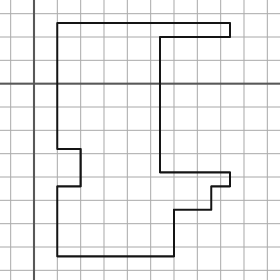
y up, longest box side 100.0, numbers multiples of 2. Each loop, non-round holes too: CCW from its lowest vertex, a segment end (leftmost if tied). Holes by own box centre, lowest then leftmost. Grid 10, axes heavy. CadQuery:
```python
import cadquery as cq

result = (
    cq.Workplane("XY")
    .moveTo(10.0, -74.0)
    .lineTo(60.0, -74.0)
    .lineTo(60.0, -54.0)
    .lineTo(76.0, -54.0)
    .lineTo(76.0, -44.0)
    .lineTo(84.0, -44.0)
    .lineTo(84.0, -38.0)
    .lineTo(54.0, -38.0)
    .lineTo(54.0, 20.0)
    .lineTo(84.0, 20.0)
    .lineTo(84.0, 26.0)
    .lineTo(10.0, 26.0)
    .lineTo(10.0, -28.0)
    .lineTo(20.0, -28.0)
    .lineTo(20.0, -44.0)
    .lineTo(10.0, -44.0)
    .close()
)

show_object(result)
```